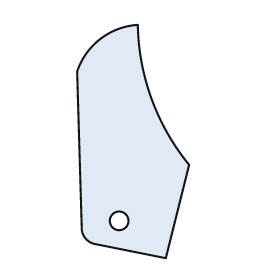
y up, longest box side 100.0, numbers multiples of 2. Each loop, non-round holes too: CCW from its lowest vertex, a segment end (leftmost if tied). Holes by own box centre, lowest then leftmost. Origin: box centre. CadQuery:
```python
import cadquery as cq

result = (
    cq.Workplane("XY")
    .moveTo(14.0, -50.0)
    .lineTo(24.0, -10.0)
    .threePointArc((8.0, 18.0), (2.0, 50.0))
    .threePointArc((-14.0, 44.0), (-24.0, 30.0))
    .lineTo(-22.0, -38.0)
    .threePointArc((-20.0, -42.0), (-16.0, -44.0))
    .close()
    .moveTo(-6.0, -34.0)
    .circle(4.0)
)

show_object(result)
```